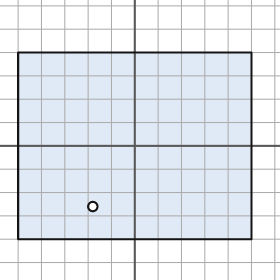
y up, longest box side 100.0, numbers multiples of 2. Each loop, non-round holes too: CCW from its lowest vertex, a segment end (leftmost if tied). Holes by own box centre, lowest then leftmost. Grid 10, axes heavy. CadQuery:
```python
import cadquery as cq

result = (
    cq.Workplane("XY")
    .moveTo(-50.0, -40.0)
    .lineTo(50.0, -40.0)
    .lineTo(50.0, 40.0)
    .lineTo(-50.0, 40.0)
    .close()
    .moveTo(-18.0, -26.0)
    .circle(2.0)
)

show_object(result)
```